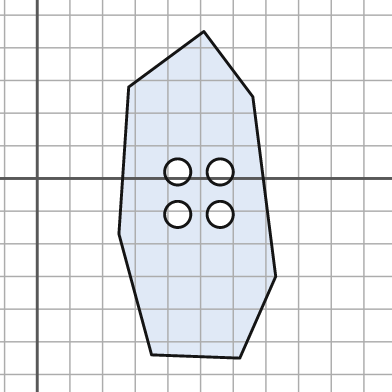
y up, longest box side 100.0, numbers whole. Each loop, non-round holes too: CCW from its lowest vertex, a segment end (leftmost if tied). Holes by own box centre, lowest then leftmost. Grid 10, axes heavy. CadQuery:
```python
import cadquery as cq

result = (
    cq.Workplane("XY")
    .moveTo(62.0, -55.0)
    .lineTo(73.0, -30.0)
    .lineTo(66.0, 25.0)
    .lineTo(51.0, 45.0)
    .lineTo(28.0, 28.0)
    .lineTo(25.0, -17.0)
    .lineTo(35.0, -54.0)
    .close()
    .moveTo(43.0, -11.0)
    .circle(4.0)
    .moveTo(56.0, -11.0)
    .circle(4.0)
    .moveTo(43.0, 2.0)
    .circle(4.0)
    .moveTo(56.0, 2.0)
    .circle(4.0)
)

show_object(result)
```